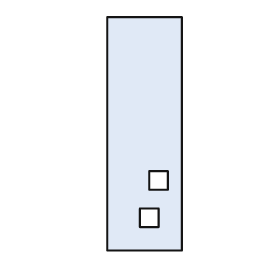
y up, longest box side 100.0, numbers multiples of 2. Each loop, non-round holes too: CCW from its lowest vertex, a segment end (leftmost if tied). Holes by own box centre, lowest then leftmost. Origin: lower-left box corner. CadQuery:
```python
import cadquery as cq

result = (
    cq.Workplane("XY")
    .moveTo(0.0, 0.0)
    .lineTo(32.0, 0.0)
    .lineTo(32.0, 100.0)
    .lineTo(0.0, 100.0)
    .close()
    .moveTo(14.0, 10.0)
    .lineTo(22.0, 10.0)
    .lineTo(22.0, 18.0)
    .lineTo(14.0, 18.0)
    .close()
    .moveTo(18.0, 26.0)
    .lineTo(26.0, 26.0)
    .lineTo(26.0, 34.0)
    .lineTo(18.0, 34.0)
    .close()
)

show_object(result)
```